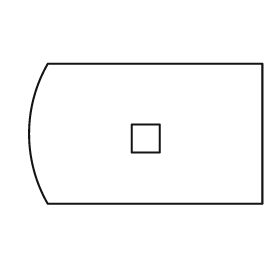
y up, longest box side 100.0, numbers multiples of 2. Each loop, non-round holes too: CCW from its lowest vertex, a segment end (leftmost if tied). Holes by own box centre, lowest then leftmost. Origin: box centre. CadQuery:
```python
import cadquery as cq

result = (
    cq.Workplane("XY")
    .moveTo(-42.0, -30.0)
    .lineTo(50.0, -30.0)
    .lineTo(50.0, 30.0)
    .lineTo(-42.0, 30.0)
    .threePointArc((-50.0, 0.0), (-42.0, -30.0))
    .close()
    .moveTo(-6.0, -8.0)
    .lineTo(6.0, -8.0)
    .lineTo(6.0, 4.0)
    .lineTo(-6.0, 4.0)
    .close()
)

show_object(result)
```